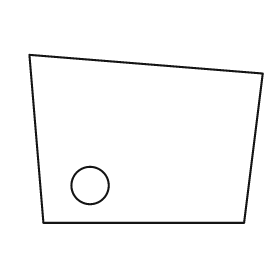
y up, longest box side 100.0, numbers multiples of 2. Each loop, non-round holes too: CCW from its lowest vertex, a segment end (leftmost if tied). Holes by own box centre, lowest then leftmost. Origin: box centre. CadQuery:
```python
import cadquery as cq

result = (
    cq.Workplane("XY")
    .moveTo(-44.0, -36.0)
    .lineTo(42.0, -36.0)
    .lineTo(50.0, 28.0)
    .lineTo(-50.0, 36.0)
    .close()
    .moveTo(-24.0, -20.0)
    .circle(8.0)
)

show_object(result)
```